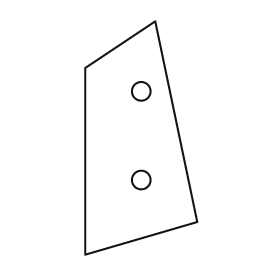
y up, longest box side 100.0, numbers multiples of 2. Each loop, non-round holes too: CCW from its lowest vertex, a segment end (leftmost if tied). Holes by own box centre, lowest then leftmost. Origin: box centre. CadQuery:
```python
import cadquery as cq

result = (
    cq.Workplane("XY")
    .moveTo(-24.0, -50.0)
    .lineTo(24.0, -36.0)
    .lineTo(6.0, 50.0)
    .lineTo(-24.0, 30.0)
    .close()
    .moveTo(0.0, -18.0)
    .circle(4.0)
    .moveTo(0.0, 20.0)
    .circle(4.0)
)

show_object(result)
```